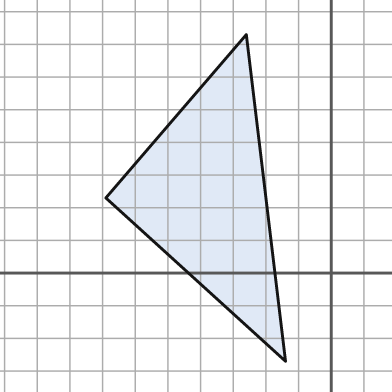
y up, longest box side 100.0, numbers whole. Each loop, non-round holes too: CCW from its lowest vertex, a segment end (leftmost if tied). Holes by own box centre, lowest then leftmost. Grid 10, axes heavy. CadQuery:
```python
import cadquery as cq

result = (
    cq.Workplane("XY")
    .moveTo(-14.0, -27.0)
    .lineTo(-26.0, 73.0)
    .lineTo(-69.0, 23.0)
    .close()
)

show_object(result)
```